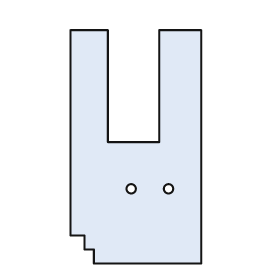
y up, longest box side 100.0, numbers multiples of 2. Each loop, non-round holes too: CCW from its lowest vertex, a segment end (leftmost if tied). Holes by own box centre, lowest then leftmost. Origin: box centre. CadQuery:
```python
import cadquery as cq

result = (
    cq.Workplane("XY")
    .moveTo(-18.0, -50.0)
    .lineTo(28.0, -50.0)
    .lineTo(28.0, 50.0)
    .lineTo(10.0, 50.0)
    .lineTo(10.0, 2.0)
    .lineTo(-12.0, 2.0)
    .lineTo(-12.0, 50.0)
    .lineTo(-28.0, 50.0)
    .lineTo(-28.0, -38.0)
    .lineTo(-22.0, -38.0)
    .lineTo(-22.0, -44.0)
    .lineTo(-18.0, -44.0)
    .close()
    .moveTo(-2.0, -18.0)
    .circle(2.0)
    .moveTo(14.0, -18.0)
    .circle(2.0)
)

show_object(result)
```